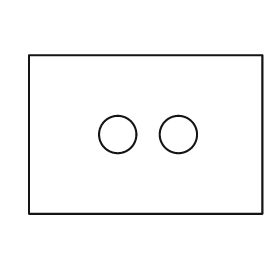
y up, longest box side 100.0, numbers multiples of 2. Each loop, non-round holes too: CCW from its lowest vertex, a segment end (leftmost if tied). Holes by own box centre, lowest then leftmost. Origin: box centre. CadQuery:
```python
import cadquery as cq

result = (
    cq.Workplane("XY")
    .moveTo(-50.0, -34.0)
    .lineTo(50.0, -34.0)
    .lineTo(50.0, 34.0)
    .lineTo(-50.0, 34.0)
    .close()
    .moveTo(-12.0, 0.0)
    .circle(8.0)
    .moveTo(14.0, 0.0)
    .circle(8.0)
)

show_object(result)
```